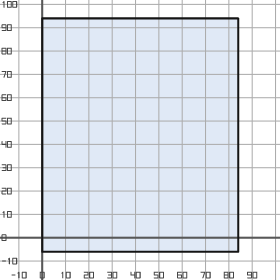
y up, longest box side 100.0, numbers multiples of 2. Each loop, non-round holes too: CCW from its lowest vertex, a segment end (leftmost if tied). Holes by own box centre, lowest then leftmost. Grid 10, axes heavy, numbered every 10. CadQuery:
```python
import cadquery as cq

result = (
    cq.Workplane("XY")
    .moveTo(0.0, -6.0)
    .lineTo(84.0, -6.0)
    .lineTo(84.0, 94.0)
    .lineTo(0.0, 94.0)
    .close()
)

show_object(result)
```